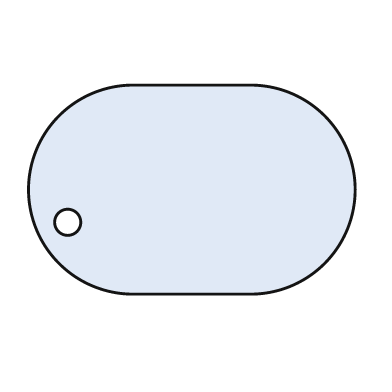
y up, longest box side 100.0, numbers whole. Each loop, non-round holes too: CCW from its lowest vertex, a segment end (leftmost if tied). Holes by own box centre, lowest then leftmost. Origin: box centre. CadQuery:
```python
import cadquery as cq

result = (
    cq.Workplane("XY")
    .moveTo(-18.0, -32.0)
    .lineTo(18.0, -32.0)
    .threePointArc((50.0, 0.0), (18.0, 32.0))
    .lineTo(-18.0, 32.0)
    .threePointArc((-50.0, 0.0), (-18.0, -32.0))
    .close()
    .moveTo(-38.0, -10.0)
    .circle(4.0)
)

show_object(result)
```